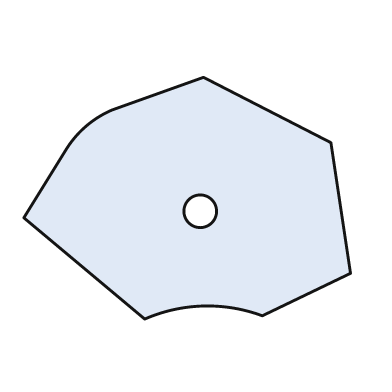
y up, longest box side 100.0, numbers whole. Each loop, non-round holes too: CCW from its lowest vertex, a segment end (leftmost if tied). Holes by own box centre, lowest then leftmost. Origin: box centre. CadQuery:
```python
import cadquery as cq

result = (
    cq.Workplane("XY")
    .moveTo(-13.0, -37.0)
    .threePointArc((5.0, -33.0), (23.0, -36.0))
    .lineTo(50.0, -23.0)
    .lineTo(44.0, 17.0)
    .lineTo(5.0, 37.0)
    .lineTo(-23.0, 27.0)
    .threePointArc((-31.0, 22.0), (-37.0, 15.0))
    .lineTo(-50.0, -6.0)
    .close()
    .moveTo(4.0, -4.0)
    .circle(5.0)
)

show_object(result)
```